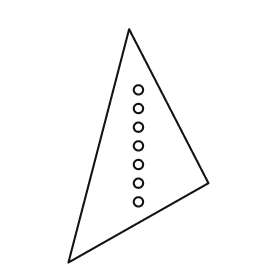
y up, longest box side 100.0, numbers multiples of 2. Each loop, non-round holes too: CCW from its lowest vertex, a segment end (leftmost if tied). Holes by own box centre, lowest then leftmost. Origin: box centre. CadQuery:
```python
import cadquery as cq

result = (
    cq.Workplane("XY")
    .moveTo(-30.0, -50.0)
    .lineTo(30.0, -16.0)
    .lineTo(-4.0, 50.0)
    .close()
    .moveTo(0.0, -24.0)
    .circle(2.0)
    .moveTo(0.0, -16.0)
    .circle(2.0)
    .moveTo(0.0, -8.0)
    .circle(2.0)
    .moveTo(0.0, 0.0)
    .circle(2.0)
    .moveTo(0.0, 8.0)
    .circle(2.0)
    .moveTo(0.0, 16.0)
    .circle(2.0)
    .moveTo(0.0, 24.0)
    .circle(2.0)
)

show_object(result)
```